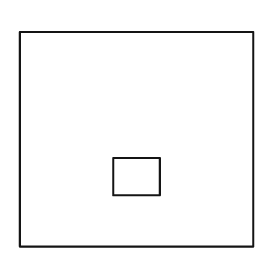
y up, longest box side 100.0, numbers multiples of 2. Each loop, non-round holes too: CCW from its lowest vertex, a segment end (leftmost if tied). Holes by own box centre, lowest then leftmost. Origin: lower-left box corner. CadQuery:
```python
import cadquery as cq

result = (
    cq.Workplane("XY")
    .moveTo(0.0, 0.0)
    .lineTo(100.0, 0.0)
    .lineTo(100.0, 92.0)
    .lineTo(0.0, 92.0)
    .close()
    .moveTo(40.0, 22.0)
    .lineTo(60.0, 22.0)
    .lineTo(60.0, 38.0)
    .lineTo(40.0, 38.0)
    .close()
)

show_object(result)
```